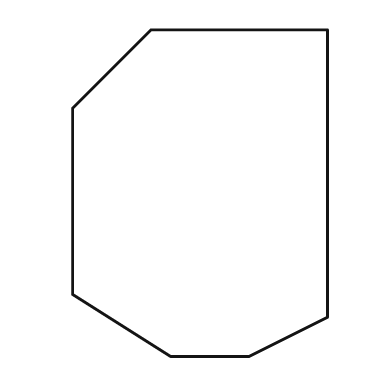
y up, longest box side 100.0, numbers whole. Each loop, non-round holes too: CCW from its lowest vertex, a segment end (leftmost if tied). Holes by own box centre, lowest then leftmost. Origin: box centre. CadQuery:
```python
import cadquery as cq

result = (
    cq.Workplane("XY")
    .moveTo(-9.0, -50.0)
    .lineTo(15.0, -50.0)
    .lineTo(39.0, -38.0)
    .lineTo(39.0, 50.0)
    .lineTo(-15.0, 50.0)
    .lineTo(-39.0, 26.0)
    .lineTo(-39.0, -31.0)
    .close()
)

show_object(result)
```